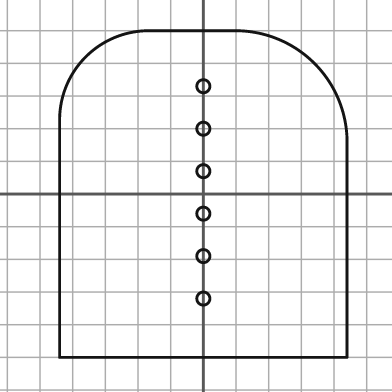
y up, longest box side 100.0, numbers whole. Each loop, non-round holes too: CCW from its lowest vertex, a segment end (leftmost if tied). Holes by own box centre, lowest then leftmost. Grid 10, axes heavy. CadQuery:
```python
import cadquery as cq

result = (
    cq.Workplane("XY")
    .moveTo(-44.0, -50.0)
    .lineTo(44.0, -50.0)
    .lineTo(44.0, 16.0)
    .threePointArc((34.0, 40.0), (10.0, 50.0))
    .lineTo(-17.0, 50.0)
    .threePointArc((-36.0, 42.0), (-44.0, 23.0))
    .close()
    .moveTo(0.0, -32.0)
    .circle(2.0)
    .moveTo(0.0, -19.0)
    .circle(2.0)
    .moveTo(0.0, -6.0)
    .circle(2.0)
    .moveTo(0.0, 7.0)
    .circle(2.0)
    .moveTo(0.0, 20.0)
    .circle(2.0)
    .moveTo(0.0, 33.0)
    .circle(2.0)
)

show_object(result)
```